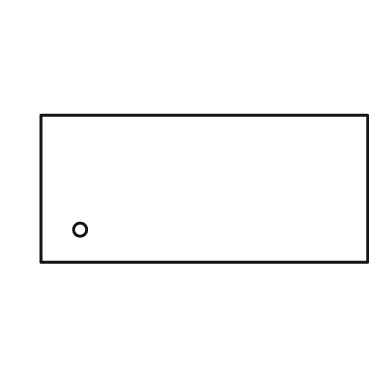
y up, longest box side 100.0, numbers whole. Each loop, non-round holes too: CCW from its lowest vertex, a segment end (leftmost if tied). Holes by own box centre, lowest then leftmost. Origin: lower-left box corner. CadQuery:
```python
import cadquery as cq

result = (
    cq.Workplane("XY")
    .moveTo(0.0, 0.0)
    .lineTo(100.0, 0.0)
    .lineTo(100.0, 45.0)
    .lineTo(0.0, 45.0)
    .close()
    .moveTo(12.0, 10.0)
    .circle(2.0)
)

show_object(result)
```